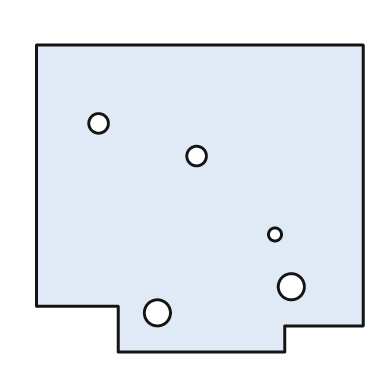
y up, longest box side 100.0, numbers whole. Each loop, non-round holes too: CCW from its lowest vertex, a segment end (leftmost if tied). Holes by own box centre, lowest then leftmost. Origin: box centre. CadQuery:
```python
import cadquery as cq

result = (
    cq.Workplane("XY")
    .moveTo(-25.0, -47.0)
    .lineTo(26.0, -47.0)
    .lineTo(26.0, -39.0)
    .lineTo(50.0, -39.0)
    .lineTo(50.0, 47.0)
    .lineTo(-50.0, 47.0)
    .lineTo(-50.0, -33.0)
    .lineTo(-25.0, -33.0)
    .close()
    .moveTo(-13.0, -35.0)
    .circle(4.0)
    .moveTo(28.0, -27.0)
    .circle(4.0)
    .moveTo(23.0, -11.0)
    .circle(2.0)
    .moveTo(-1.0, 13.0)
    .circle(3.0)
    .moveTo(-31.0, 23.0)
    .circle(3.0)
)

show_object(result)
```